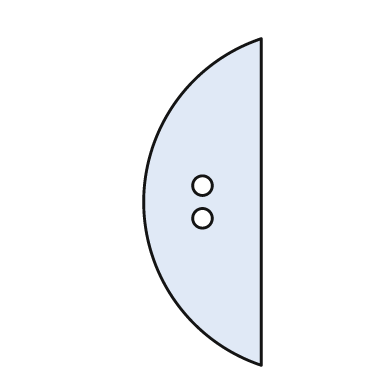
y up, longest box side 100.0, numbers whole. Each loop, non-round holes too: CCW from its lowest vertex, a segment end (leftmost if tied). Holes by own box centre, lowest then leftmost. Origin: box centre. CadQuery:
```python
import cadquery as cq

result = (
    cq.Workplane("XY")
    .moveTo(18.0, -50.0)
    .lineTo(18.0, 50.0)
    .threePointArc((-18.0, 0.0), (18.0, -50.0))
    .close()
    .moveTo(0.0, -5.0)
    .circle(3.0)
    .moveTo(0.0, 5.0)
    .circle(3.0)
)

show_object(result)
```